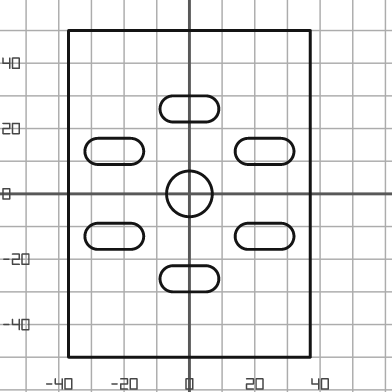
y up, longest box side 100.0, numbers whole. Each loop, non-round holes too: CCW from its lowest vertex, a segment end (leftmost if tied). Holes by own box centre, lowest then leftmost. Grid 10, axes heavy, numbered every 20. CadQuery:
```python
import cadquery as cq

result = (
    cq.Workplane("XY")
    .moveTo(-37.0, -50.0)
    .lineTo(37.0, -50.0)
    .lineTo(37.0, 50.0)
    .lineTo(-37.0, 50.0)
    .close()
    .moveTo(-5.0, -30.0)
    .lineTo(5.0, -30.0)
    .threePointArc((9.0, -26.0), (5.0, -22.0))
    .lineTo(-5.0, -22.0)
    .threePointArc((-9.0, -26.0), (-5.0, -30.0))
    .close()
    .moveTo(-28.0, -17.0)
    .lineTo(-18.0, -17.0)
    .threePointArc((-14.0, -13.0), (-18.0, -9.0))
    .lineTo(-28.0, -9.0)
    .threePointArc((-32.0, -13.0), (-28.0, -17.0))
    .close()
    .moveTo(18.0, -17.0)
    .lineTo(28.0, -17.0)
    .threePointArc((32.0, -13.0), (28.0, -9.0))
    .lineTo(18.0, -9.0)
    .threePointArc((14.0, -13.0), (18.0, -17.0))
    .close()
    .moveTo(0.0, 0.0)
    .circle(7.0)
    .moveTo(-28.0, 9.0)
    .lineTo(-18.0, 9.0)
    .threePointArc((-14.0, 13.0), (-18.0, 17.0))
    .lineTo(-28.0, 17.0)
    .threePointArc((-32.0, 13.0), (-28.0, 9.0))
    .close()
    .moveTo(18.0, 9.0)
    .lineTo(28.0, 9.0)
    .threePointArc((32.0, 13.0), (28.0, 17.0))
    .lineTo(18.0, 17.0)
    .threePointArc((14.0, 13.0), (18.0, 9.0))
    .close()
    .moveTo(-5.0, 22.0)
    .lineTo(5.0, 22.0)
    .threePointArc((9.0, 26.0), (5.0, 30.0))
    .lineTo(-5.0, 30.0)
    .threePointArc((-9.0, 26.0), (-5.0, 22.0))
    .close()
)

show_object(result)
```